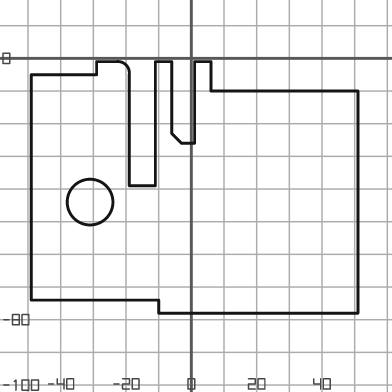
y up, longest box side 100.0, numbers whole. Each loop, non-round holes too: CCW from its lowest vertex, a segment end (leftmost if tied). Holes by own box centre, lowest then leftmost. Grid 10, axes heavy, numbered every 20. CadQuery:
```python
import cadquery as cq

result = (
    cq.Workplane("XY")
    .moveTo(-10.0, -78.0)
    .lineTo(51.0, -78.0)
    .lineTo(51.0, -10.0)
    .lineTo(6.0, -10.0)
    .lineTo(6.0, -1.0)
    .lineTo(1.0, -1.0)
    .lineTo(1.0, -26.0)
    .lineTo(-3.0, -26.0)
    .lineTo(-6.0, -23.0)
    .lineTo(-6.0, -1.0)
    .lineTo(-11.0, -1.0)
    .lineTo(-11.0, -39.0)
    .lineTo(-19.0, -39.0)
    .lineTo(-19.0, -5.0)
    .threePointArc((-20.0, -2.0), (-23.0, -1.0))
    .lineTo(-29.0, -1.0)
    .lineTo(-29.0, -5.0)
    .lineTo(-49.0, -5.0)
    .lineTo(-49.0, -74.0)
    .lineTo(-10.0, -74.0)
    .close()
    .moveTo(-31.0, -44.0)
    .circle(7.0)
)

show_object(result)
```